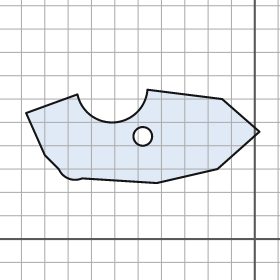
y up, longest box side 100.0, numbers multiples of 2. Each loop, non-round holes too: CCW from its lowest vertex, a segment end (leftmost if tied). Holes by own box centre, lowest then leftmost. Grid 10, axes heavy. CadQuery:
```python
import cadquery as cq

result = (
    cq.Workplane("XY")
    .moveTo(-42.0, 24.0)
    .lineTo(-16.0, 30.0)
    .lineTo(2.0, 46.0)
    .lineTo(-14.0, 60.0)
    .lineTo(-46.0, 64.0)
    .threePointArc((-60.0, 50.0), (-76.0, 62.0))
    .lineTo(-98.0, 54.0)
    .lineTo(-90.0, 36.0)
    .lineTo(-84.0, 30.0)
    .threePointArc((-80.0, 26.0), (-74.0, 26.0))
    .close()
    .moveTo(-48.0, 44.0)
    .circle(4.0)
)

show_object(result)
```